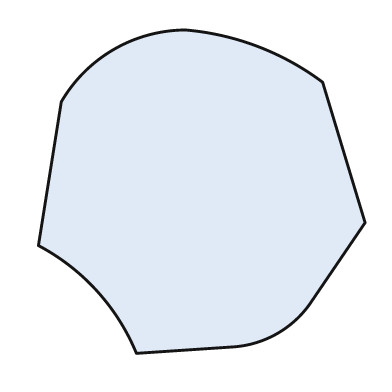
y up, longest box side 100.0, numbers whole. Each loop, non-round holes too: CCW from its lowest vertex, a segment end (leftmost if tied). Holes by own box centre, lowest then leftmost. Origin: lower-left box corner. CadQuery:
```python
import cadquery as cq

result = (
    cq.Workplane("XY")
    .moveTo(30.0, 0.0)
    .lineTo(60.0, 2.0)
    .threePointArc((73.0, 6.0), (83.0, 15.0))
    .lineTo(100.0, 40.0)
    .lineTo(87.0, 83.0)
    .threePointArc((67.0, 94.0), (45.0, 99.0))
    .threePointArc((23.0, 93.0), (7.0, 77.0))
    .lineTo(0.0, 33.0)
    .threePointArc((18.0, 19.0), (30.0, 0.0))
    .close()
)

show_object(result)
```